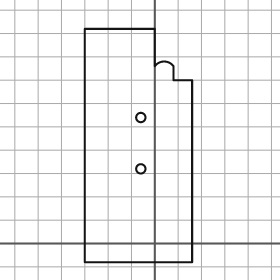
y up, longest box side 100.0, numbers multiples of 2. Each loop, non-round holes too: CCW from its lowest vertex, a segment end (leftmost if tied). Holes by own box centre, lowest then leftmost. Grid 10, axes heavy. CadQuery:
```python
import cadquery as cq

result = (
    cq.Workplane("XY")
    .moveTo(-30.0, -8.0)
    .lineTo(16.0, -8.0)
    .lineTo(16.0, 70.0)
    .lineTo(8.0, 70.0)
    .lineTo(8.0, 76.0)
    .threePointArc((4.0, 78.0), (0.0, 76.0))
    .lineTo(0.0, 92.0)
    .lineTo(-30.0, 92.0)
    .close()
    .moveTo(-6.0, 32.0)
    .circle(2.0)
    .moveTo(-6.0, 54.0)
    .circle(2.0)
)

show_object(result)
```